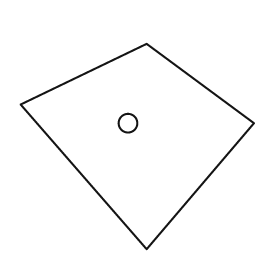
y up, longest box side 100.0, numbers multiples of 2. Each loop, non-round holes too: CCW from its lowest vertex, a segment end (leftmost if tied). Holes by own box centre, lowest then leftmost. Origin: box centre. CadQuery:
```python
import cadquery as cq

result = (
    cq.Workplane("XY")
    .moveTo(4.0, -44.0)
    .lineTo(50.0, 10.0)
    .lineTo(4.0, 44.0)
    .lineTo(-50.0, 18.0)
    .close()
    .moveTo(-4.0, 10.0)
    .circle(4.0)
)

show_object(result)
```